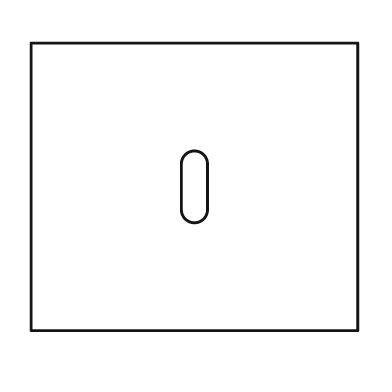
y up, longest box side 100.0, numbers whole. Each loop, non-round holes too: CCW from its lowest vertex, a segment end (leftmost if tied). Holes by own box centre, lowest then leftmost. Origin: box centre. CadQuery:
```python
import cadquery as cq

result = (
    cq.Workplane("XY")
    .moveTo(-50.0, -44.0)
    .lineTo(50.0, -44.0)
    .lineTo(50.0, 44.0)
    .lineTo(-50.0, 44.0)
    .close()
    .moveTo(-4.0, -7.0)
    .threePointArc((0.0, -11.0), (4.0, -7.0))
    .lineTo(4.0, 7.0)
    .threePointArc((0.0, 11.0), (-4.0, 7.0))
    .close()
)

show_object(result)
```